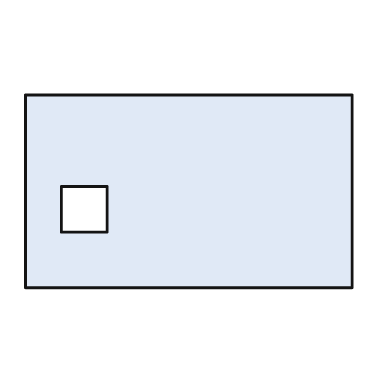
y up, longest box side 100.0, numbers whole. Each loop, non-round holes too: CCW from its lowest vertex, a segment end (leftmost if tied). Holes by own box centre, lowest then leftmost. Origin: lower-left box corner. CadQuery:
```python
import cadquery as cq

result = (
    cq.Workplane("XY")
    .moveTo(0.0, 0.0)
    .lineTo(100.0, 0.0)
    .lineTo(100.0, 59.0)
    .lineTo(0.0, 59.0)
    .close()
    .moveTo(11.0, 17.0)
    .lineTo(25.0, 17.0)
    .lineTo(25.0, 31.0)
    .lineTo(11.0, 31.0)
    .close()
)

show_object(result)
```